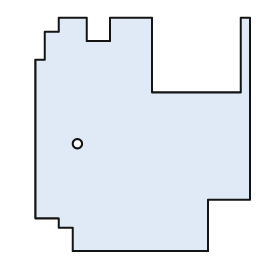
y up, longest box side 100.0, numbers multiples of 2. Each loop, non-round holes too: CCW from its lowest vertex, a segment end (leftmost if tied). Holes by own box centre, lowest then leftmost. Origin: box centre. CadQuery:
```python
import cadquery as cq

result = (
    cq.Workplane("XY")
    .moveTo(-30.0, -50.0)
    .lineTo(28.0, -50.0)
    .lineTo(28.0, -28.0)
    .lineTo(46.0, -28.0)
    .lineTo(46.0, 50.0)
    .lineTo(42.0, 50.0)
    .lineTo(42.0, 18.0)
    .lineTo(4.0, 18.0)
    .lineTo(4.0, 50.0)
    .lineTo(-14.0, 50.0)
    .lineTo(-14.0, 40.0)
    .lineTo(-24.0, 40.0)
    .lineTo(-24.0, 50.0)
    .lineTo(-36.0, 50.0)
    .lineTo(-36.0, 44.0)
    .lineTo(-42.0, 44.0)
    .lineTo(-42.0, 32.0)
    .lineTo(-46.0, 32.0)
    .lineTo(-46.0, -36.0)
    .lineTo(-36.0, -36.0)
    .lineTo(-36.0, -40.0)
    .lineTo(-30.0, -40.0)
    .close()
    .moveTo(-28.0, -4.0)
    .circle(2.0)
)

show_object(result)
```